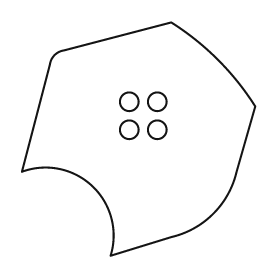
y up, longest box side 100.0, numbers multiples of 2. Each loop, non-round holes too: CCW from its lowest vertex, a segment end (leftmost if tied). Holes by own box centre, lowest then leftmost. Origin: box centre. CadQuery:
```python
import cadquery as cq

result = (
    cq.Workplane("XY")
    .moveTo(-12.0, -50.0)
    .lineTo(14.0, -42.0)
    .threePointArc((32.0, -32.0), (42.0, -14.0))
    .lineTo(50.0, 14.0)
    .threePointArc((34.0, 34.0), (14.0, 50.0))
    .lineTo(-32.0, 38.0)
    .threePointArc((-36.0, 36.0), (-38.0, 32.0))
    .lineTo(-50.0, -14.0)
    .threePointArc((-20.0, -20.0), (-12.0, -50.0))
    .close()
    .moveTo(-4.0, 4.0)
    .circle(4.0)
    .moveTo(8.0, 4.0)
    .circle(4.0)
    .moveTo(-4.0, 16.0)
    .circle(4.0)
    .moveTo(8.0, 16.0)
    .circle(4.0)
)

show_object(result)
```